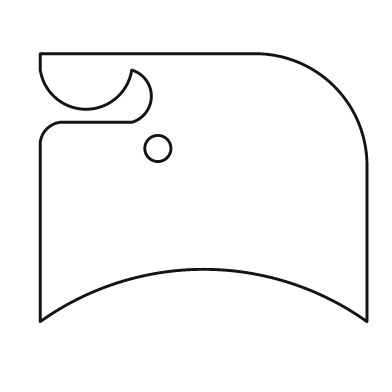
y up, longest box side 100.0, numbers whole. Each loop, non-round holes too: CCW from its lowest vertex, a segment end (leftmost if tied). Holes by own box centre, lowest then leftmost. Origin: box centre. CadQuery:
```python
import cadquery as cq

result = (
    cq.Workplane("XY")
    .moveTo(-50.0, -41.0)
    .threePointArc((0.0, -25.0), (50.0, -41.0))
    .lineTo(50.0, 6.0)
    .threePointArc((40.0, 31.0), (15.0, 41.0))
    .lineTo(-50.0, 41.0)
    .lineTo(-50.0, 36.0)
    .threePointArc((-36.0, 24.0), (-22.0, 36.0))
    .threePointArc((-16.0, 28.0), (-22.0, 20.0))
    .lineTo(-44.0, 20.0)
    .threePointArc((-48.0, 18.0), (-50.0, 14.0))
    .close()
    .moveTo(-14.0, 12.0)
    .circle(4.0)
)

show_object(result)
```